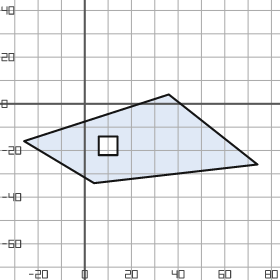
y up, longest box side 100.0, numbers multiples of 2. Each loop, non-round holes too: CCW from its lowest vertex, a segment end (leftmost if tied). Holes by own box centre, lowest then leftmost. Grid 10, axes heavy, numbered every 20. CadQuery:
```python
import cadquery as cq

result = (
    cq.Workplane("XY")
    .moveTo(4.0, -34.0)
    .lineTo(74.0, -26.0)
    .lineTo(36.0, 4.0)
    .lineTo(-26.0, -16.0)
    .close()
    .moveTo(6.0, -22.0)
    .lineTo(14.0, -22.0)
    .lineTo(14.0, -14.0)
    .lineTo(6.0, -14.0)
    .close()
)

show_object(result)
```